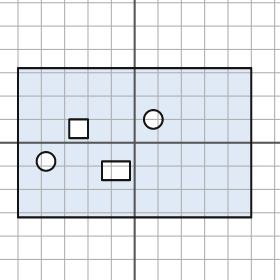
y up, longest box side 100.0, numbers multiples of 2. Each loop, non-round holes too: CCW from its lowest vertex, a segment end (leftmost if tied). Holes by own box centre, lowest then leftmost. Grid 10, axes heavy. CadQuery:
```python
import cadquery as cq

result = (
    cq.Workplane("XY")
    .moveTo(-50.0, -32.0)
    .lineTo(50.0, -32.0)
    .lineTo(50.0, 32.0)
    .lineTo(-50.0, 32.0)
    .close()
    .moveTo(-14.0, -16.0)
    .lineTo(-2.0, -16.0)
    .lineTo(-2.0, -8.0)
    .lineTo(-14.0, -8.0)
    .close()
    .moveTo(-38.0, -8.0)
    .circle(4.0)
    .moveTo(-28.0, 2.0)
    .lineTo(-20.0, 2.0)
    .lineTo(-20.0, 10.0)
    .lineTo(-28.0, 10.0)
    .close()
    .moveTo(8.0, 10.0)
    .circle(4.0)
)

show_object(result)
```